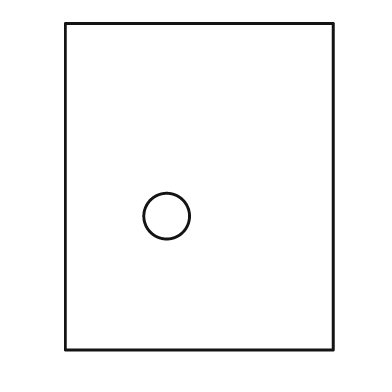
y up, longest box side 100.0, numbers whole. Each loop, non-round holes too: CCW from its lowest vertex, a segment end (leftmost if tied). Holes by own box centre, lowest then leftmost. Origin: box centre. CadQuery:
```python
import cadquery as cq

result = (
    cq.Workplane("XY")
    .moveTo(-41.0, -50.0)
    .lineTo(41.0, -50.0)
    .lineTo(41.0, 50.0)
    .lineTo(-41.0, 50.0)
    .close()
    .moveTo(-10.0, -9.0)
    .circle(7.0)
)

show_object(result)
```